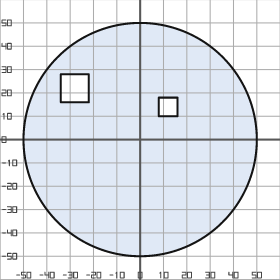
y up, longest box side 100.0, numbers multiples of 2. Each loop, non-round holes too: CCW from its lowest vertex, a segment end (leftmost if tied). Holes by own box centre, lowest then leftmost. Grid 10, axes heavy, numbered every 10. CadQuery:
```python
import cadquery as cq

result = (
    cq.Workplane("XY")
    .moveTo(0.0, 0.0)
    .circle(50.0)
    .moveTo(8.0, 10.0)
    .lineTo(16.0, 10.0)
    .lineTo(16.0, 18.0)
    .lineTo(8.0, 18.0)
    .close()
    .moveTo(-34.0, 16.0)
    .lineTo(-22.0, 16.0)
    .lineTo(-22.0, 28.0)
    .lineTo(-34.0, 28.0)
    .close()
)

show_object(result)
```